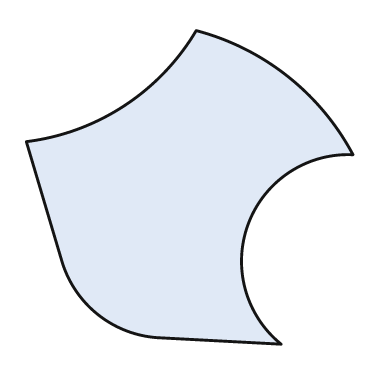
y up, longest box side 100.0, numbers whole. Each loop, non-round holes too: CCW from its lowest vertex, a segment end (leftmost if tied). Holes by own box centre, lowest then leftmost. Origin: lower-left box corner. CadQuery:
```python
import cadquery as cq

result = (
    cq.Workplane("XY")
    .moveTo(78.0, 0.0)
    .threePointArc((68.0, 37.0), (100.0, 58.0))
    .threePointArc((80.0, 82.0), (52.0, 96.0))
    .threePointArc((30.0, 73.0), (0.0, 62.0))
    .lineTo(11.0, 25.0)
    .threePointArc((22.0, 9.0), (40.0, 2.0))
    .close()
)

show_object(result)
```